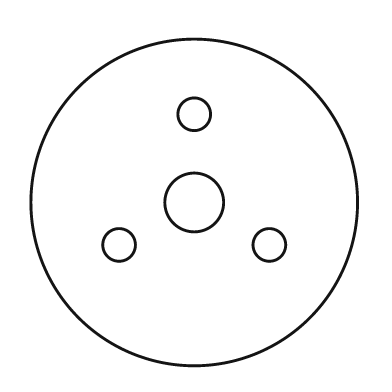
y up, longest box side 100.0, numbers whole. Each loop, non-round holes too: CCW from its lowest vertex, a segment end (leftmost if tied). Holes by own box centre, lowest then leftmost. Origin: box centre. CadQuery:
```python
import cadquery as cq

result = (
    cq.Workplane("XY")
    .moveTo(0.0, 0.0)
    .circle(50.0)
    .moveTo(-23.0, -13.0)
    .circle(5.0)
    .moveTo(23.0, -13.0)
    .circle(5.0)
    .moveTo(0.0, 0.0)
    .circle(9.0)
    .moveTo(0.0, 27.0)
    .circle(5.0)
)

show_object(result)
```